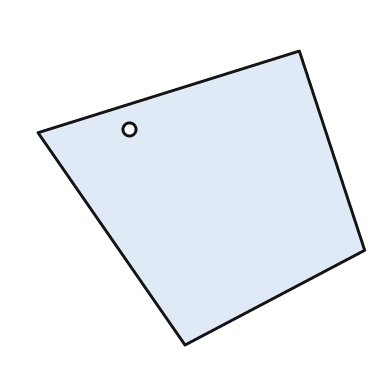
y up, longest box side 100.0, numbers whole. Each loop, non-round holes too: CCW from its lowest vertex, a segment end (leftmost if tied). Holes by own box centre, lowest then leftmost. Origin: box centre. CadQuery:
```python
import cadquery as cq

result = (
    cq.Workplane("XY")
    .moveTo(-5.0, -45.0)
    .lineTo(50.0, -16.0)
    .lineTo(30.0, 45.0)
    .lineTo(-50.0, 20.0)
    .close()
    .moveTo(-22.0, 21.0)
    .circle(2.0)
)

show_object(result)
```